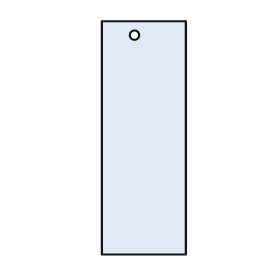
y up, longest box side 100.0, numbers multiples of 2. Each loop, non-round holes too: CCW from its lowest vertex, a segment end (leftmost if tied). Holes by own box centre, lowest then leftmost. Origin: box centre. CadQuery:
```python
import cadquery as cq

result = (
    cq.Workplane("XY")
    .moveTo(-18.0, -50.0)
    .lineTo(18.0, -50.0)
    .lineTo(18.0, 50.0)
    .lineTo(-18.0, 50.0)
    .close()
    .moveTo(-4.0, 44.0)
    .circle(2.0)
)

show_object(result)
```